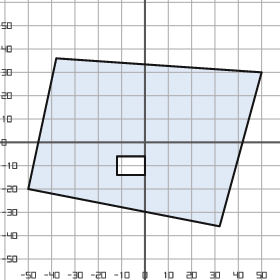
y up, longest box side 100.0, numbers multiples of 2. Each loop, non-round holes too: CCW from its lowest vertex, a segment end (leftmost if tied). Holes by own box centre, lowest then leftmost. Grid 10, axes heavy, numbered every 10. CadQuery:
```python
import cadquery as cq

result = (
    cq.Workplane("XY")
    .moveTo(32.0, -36.0)
    .lineTo(50.0, 30.0)
    .lineTo(-38.0, 36.0)
    .lineTo(-50.0, -20.0)
    .close()
    .moveTo(-12.0, -14.0)
    .lineTo(0.0, -14.0)
    .lineTo(0.0, -6.0)
    .lineTo(-12.0, -6.0)
    .close()
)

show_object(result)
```